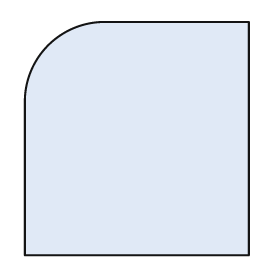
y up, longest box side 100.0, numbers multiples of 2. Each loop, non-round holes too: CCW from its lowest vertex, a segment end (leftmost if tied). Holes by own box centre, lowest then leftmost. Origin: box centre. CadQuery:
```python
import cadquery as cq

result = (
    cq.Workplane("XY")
    .moveTo(-48.0, -50.0)
    .lineTo(48.0, -50.0)
    .lineTo(48.0, 50.0)
    .lineTo(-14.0, 50.0)
    .threePointArc((-38.0, 40.0), (-48.0, 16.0))
    .close()
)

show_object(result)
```